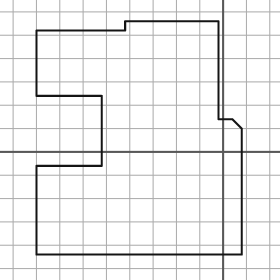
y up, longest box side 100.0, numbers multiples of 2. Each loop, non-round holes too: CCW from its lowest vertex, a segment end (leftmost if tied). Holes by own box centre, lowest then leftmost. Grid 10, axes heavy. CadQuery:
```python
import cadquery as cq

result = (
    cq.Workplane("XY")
    .moveTo(-80.0, -44.0)
    .lineTo(8.0, -44.0)
    .lineTo(8.0, 10.0)
    .lineTo(4.0, 14.0)
    .lineTo(-2.0, 14.0)
    .lineTo(-2.0, 56.0)
    .lineTo(-42.0, 56.0)
    .lineTo(-42.0, 52.0)
    .lineTo(-80.0, 52.0)
    .lineTo(-80.0, 24.0)
    .lineTo(-52.0, 24.0)
    .lineTo(-52.0, -6.0)
    .lineTo(-80.0, -6.0)
    .close()
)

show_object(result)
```